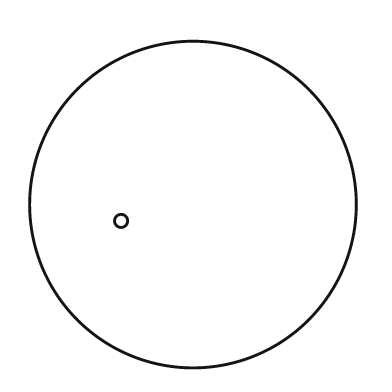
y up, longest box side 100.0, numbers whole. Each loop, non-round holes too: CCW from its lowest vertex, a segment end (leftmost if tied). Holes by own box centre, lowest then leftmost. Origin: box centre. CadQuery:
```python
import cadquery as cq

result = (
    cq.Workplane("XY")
    .moveTo(0.0, 0.0)
    .circle(50.0)
    .moveTo(-22.0, -5.0)
    .circle(2.0)
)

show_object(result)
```